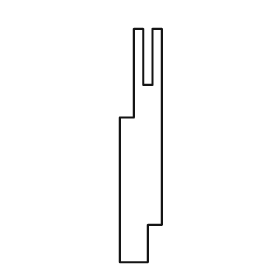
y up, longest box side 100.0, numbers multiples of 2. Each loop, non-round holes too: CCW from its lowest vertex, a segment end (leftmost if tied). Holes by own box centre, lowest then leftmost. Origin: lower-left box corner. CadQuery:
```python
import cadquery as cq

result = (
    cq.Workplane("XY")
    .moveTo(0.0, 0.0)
    .lineTo(12.0, 0.0)
    .lineTo(12.0, 16.0)
    .lineTo(18.0, 16.0)
    .lineTo(18.0, 100.0)
    .lineTo(14.0, 100.0)
    .lineTo(14.0, 76.0)
    .lineTo(10.0, 76.0)
    .lineTo(10.0, 100.0)
    .lineTo(6.0, 100.0)
    .lineTo(6.0, 62.0)
    .lineTo(0.0, 62.0)
    .close()
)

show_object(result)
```